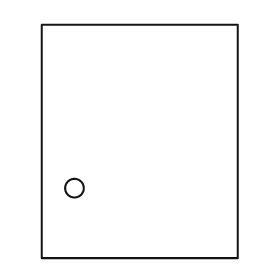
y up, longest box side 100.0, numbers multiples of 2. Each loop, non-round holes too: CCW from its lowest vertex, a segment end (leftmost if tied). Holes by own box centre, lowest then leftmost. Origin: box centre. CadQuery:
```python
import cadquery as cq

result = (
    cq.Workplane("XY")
    .moveTo(-42.0, -50.0)
    .lineTo(42.0, -50.0)
    .lineTo(42.0, 50.0)
    .lineTo(-42.0, 50.0)
    .close()
    .moveTo(-28.0, -20.0)
    .circle(4.0)
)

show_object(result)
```